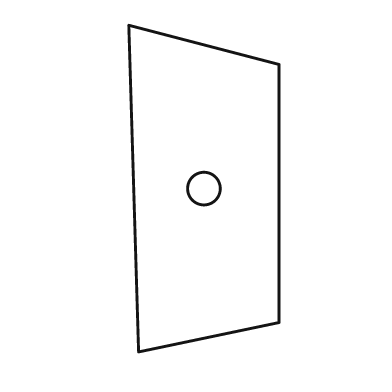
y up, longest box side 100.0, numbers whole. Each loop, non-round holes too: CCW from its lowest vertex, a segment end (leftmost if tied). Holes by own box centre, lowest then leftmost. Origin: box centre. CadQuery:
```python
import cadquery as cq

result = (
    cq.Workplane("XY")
    .moveTo(-20.0, -50.0)
    .lineTo(23.0, -41.0)
    .lineTo(23.0, 38.0)
    .lineTo(-23.0, 50.0)
    .close()
    .moveTo(0.0, 0.0)
    .circle(5.0)
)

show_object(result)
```